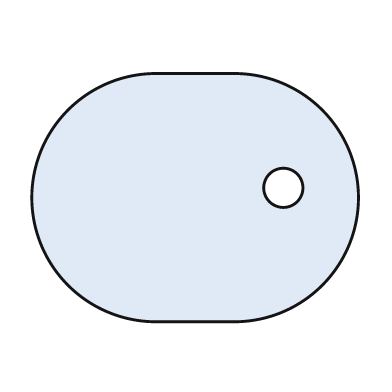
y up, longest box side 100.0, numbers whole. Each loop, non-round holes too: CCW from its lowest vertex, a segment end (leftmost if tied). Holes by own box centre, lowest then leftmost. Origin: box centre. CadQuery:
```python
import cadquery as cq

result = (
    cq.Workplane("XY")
    .moveTo(-12.0, -38.0)
    .lineTo(12.0, -38.0)
    .threePointArc((50.0, 0.0), (12.0, 38.0))
    .lineTo(-12.0, 38.0)
    .threePointArc((-50.0, 0.0), (-12.0, -38.0))
    .close()
    .moveTo(27.0, 3.0)
    .circle(6.0)
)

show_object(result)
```